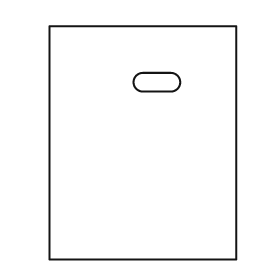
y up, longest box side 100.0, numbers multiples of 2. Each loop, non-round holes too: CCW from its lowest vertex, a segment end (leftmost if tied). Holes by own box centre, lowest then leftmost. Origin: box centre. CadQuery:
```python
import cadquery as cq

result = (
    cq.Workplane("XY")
    .moveTo(-40.0, -50.0)
    .lineTo(40.0, -50.0)
    .lineTo(40.0, 50.0)
    .lineTo(-40.0, 50.0)
    .close()
    .moveTo(0.0, 22.0)
    .lineTo(12.0, 22.0)
    .threePointArc((16.0, 26.0), (12.0, 30.0))
    .lineTo(0.0, 30.0)
    .threePointArc((-4.0, 26.0), (0.0, 22.0))
    .close()
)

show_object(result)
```